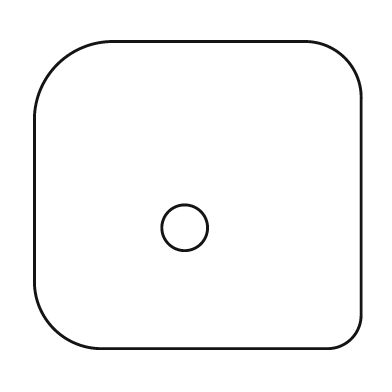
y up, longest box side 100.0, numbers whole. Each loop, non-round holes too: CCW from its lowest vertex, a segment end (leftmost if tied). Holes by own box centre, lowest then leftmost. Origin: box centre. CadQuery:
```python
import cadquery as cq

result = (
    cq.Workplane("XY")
    .moveTo(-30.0, -47.0)
    .lineTo(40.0, -47.0)
    .threePointArc((47.0, -44.0), (50.0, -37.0))
    .lineTo(50.0, 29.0)
    .threePointArc((45.0, 42.0), (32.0, 47.0))
    .lineTo(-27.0, 47.0)
    .threePointArc((-43.0, 40.0), (-50.0, 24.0))
    .lineTo(-50.0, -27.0)
    .threePointArc((-44.0, -41.0), (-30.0, -47.0))
    .close()
    .moveTo(-4.0, -10.0)
    .circle(7.0)
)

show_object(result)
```